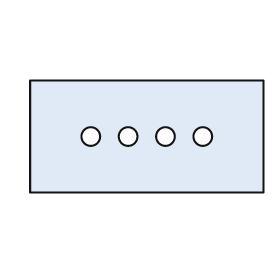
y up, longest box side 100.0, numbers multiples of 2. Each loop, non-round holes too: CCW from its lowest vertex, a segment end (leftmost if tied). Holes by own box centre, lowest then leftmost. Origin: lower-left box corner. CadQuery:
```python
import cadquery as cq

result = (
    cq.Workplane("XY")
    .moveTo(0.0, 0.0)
    .lineTo(100.0, 0.0)
    .lineTo(100.0, 48.0)
    .lineTo(0.0, 48.0)
    .close()
    .moveTo(26.0, 24.0)
    .circle(4.0)
    .moveTo(42.0, 24.0)
    .circle(4.0)
    .moveTo(58.0, 24.0)
    .circle(4.0)
    .moveTo(74.0, 24.0)
    .circle(4.0)
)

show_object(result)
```